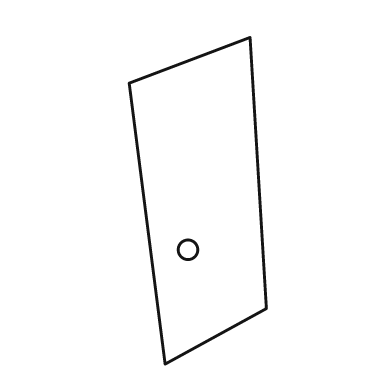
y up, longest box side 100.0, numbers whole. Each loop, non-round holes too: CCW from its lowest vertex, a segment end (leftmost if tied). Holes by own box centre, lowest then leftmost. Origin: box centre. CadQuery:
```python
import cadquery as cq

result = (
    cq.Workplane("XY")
    .moveTo(-10.0, -50.0)
    .lineTo(21.0, -33.0)
    .lineTo(16.0, 50.0)
    .lineTo(-21.0, 36.0)
    .close()
    .moveTo(-3.0, -15.0)
    .circle(3.0)
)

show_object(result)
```